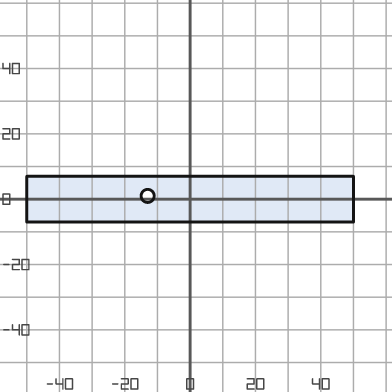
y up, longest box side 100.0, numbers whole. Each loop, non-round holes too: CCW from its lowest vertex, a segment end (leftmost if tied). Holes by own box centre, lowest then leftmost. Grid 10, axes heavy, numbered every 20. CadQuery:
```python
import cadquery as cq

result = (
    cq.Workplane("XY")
    .moveTo(-50.0, -7.0)
    .lineTo(50.0, -7.0)
    .lineTo(50.0, 7.0)
    .lineTo(-50.0, 7.0)
    .close()
    .moveTo(-13.0, 1.0)
    .circle(2.0)
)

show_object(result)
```